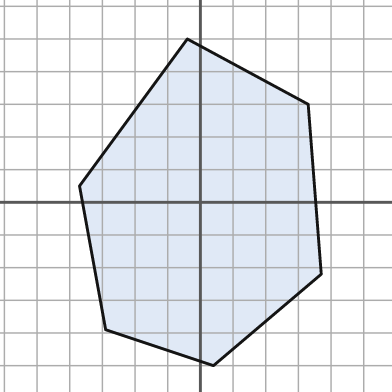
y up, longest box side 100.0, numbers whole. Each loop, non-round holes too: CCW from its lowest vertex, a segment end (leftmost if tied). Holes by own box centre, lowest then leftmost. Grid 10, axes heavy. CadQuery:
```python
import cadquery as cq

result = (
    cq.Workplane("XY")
    .moveTo(4.0, -50.0)
    .lineTo(37.0, -22.0)
    .lineTo(33.0, 30.0)
    .lineTo(-4.0, 50.0)
    .lineTo(-37.0, 5.0)
    .lineTo(-29.0, -39.0)
    .close()
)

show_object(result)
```